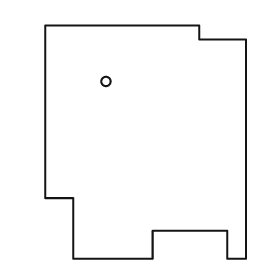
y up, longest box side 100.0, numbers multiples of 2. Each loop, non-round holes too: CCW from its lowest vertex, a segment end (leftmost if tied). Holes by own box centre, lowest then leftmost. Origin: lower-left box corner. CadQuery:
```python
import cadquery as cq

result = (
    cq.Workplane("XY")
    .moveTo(12.0, 0.0)
    .lineTo(46.0, 0.0)
    .lineTo(46.0, 12.0)
    .lineTo(78.0, 12.0)
    .lineTo(78.0, 0.0)
    .lineTo(86.0, 0.0)
    .lineTo(86.0, 94.0)
    .lineTo(66.0, 94.0)
    .lineTo(66.0, 100.0)
    .lineTo(0.0, 100.0)
    .lineTo(0.0, 26.0)
    .lineTo(12.0, 26.0)
    .close()
    .moveTo(26.0, 76.0)
    .circle(2.0)
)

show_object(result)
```